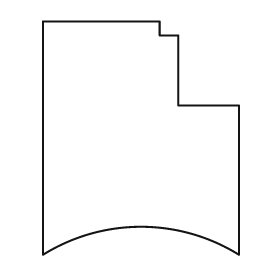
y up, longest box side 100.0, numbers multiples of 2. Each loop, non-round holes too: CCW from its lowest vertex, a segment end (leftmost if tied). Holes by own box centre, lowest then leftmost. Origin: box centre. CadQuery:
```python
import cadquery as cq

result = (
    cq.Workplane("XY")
    .moveTo(-42.0, -50.0)
    .threePointArc((0.0, -38.0), (42.0, -50.0))
    .lineTo(42.0, 14.0)
    .lineTo(16.0, 14.0)
    .lineTo(16.0, 44.0)
    .lineTo(8.0, 44.0)
    .lineTo(8.0, 50.0)
    .lineTo(-42.0, 50.0)
    .close()
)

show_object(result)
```